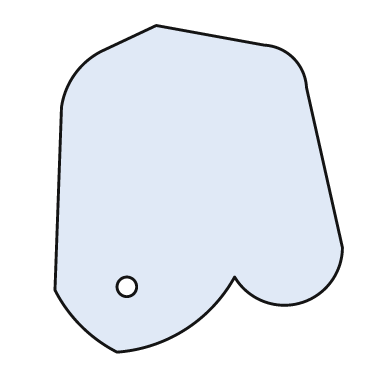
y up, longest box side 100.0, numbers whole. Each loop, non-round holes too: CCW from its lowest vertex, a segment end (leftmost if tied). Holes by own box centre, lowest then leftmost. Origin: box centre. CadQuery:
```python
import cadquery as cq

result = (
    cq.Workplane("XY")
    .moveTo(-25.0, -50.0)
    .threePointArc((-4.0, -43.0), (11.0, -27.0))
    .threePointArc((31.0, -35.0), (44.0, -18.0))
    .lineTo(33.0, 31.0)
    .threePointArc((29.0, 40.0), (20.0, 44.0))
    .lineTo(-13.0, 50.0)
    .lineTo(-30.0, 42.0)
    .threePointArc((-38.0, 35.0), (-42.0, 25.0))
    .lineTo(-44.0, -31.0)
    .threePointArc((-36.0, -42.0), (-25.0, -50.0))
    .close()
    .moveTo(-22.0, -30.0)
    .circle(3.0)
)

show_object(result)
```